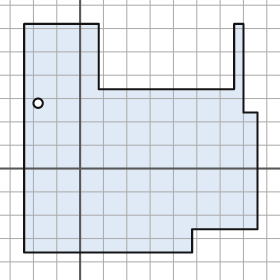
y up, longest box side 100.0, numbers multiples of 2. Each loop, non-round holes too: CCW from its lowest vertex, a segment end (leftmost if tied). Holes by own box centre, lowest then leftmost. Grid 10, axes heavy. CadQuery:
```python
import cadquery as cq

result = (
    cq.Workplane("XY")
    .moveTo(-24.0, -36.0)
    .lineTo(48.0, -36.0)
    .lineTo(48.0, -26.0)
    .lineTo(76.0, -26.0)
    .lineTo(76.0, 24.0)
    .lineTo(70.0, 24.0)
    .lineTo(70.0, 62.0)
    .lineTo(66.0, 62.0)
    .lineTo(66.0, 34.0)
    .lineTo(8.0, 34.0)
    .lineTo(8.0, 62.0)
    .lineTo(-24.0, 62.0)
    .close()
    .moveTo(-18.0, 28.0)
    .circle(2.0)
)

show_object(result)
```